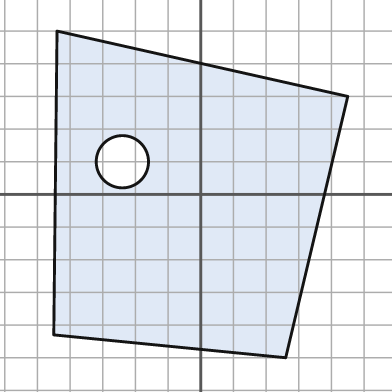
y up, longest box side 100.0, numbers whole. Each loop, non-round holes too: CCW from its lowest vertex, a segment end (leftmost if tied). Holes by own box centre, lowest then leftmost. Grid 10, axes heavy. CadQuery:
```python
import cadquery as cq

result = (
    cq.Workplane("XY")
    .moveTo(26.0, -50.0)
    .lineTo(45.0, 30.0)
    .lineTo(-44.0, 50.0)
    .lineTo(-45.0, -43.0)
    .close()
    .moveTo(-24.0, 10.0)
    .circle(8.0)
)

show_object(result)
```